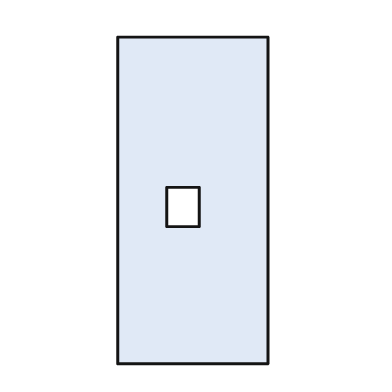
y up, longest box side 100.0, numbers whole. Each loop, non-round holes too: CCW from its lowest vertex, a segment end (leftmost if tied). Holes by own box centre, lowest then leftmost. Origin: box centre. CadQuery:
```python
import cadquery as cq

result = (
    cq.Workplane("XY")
    .moveTo(-23.0, -50.0)
    .lineTo(23.0, -50.0)
    .lineTo(23.0, 50.0)
    .lineTo(-23.0, 50.0)
    .close()
    .moveTo(-8.0, -8.0)
    .lineTo(2.0, -8.0)
    .lineTo(2.0, 4.0)
    .lineTo(-8.0, 4.0)
    .close()
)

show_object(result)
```